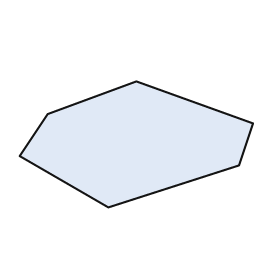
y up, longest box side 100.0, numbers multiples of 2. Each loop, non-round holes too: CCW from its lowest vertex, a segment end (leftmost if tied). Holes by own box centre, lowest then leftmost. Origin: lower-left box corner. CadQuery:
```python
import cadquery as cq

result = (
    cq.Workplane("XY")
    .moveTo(38.0, 0.0)
    .lineTo(94.0, 18.0)
    .lineTo(100.0, 36.0)
    .lineTo(50.0, 54.0)
    .lineTo(12.0, 40.0)
    .lineTo(0.0, 22.0)
    .close()
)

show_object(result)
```